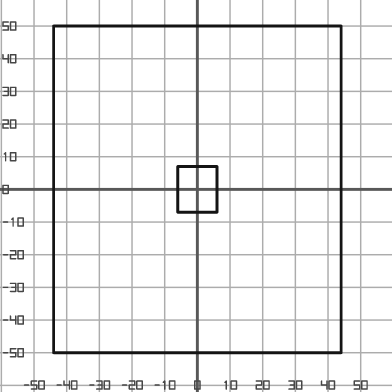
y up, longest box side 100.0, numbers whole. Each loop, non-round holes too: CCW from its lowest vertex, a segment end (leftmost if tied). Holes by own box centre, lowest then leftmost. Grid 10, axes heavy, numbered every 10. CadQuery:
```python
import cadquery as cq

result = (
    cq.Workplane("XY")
    .moveTo(-44.0, -50.0)
    .lineTo(44.0, -50.0)
    .lineTo(44.0, 50.0)
    .lineTo(-44.0, 50.0)
    .close()
    .moveTo(-6.0, -7.0)
    .lineTo(6.0, -7.0)
    .lineTo(6.0, 7.0)
    .lineTo(-6.0, 7.0)
    .close()
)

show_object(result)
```